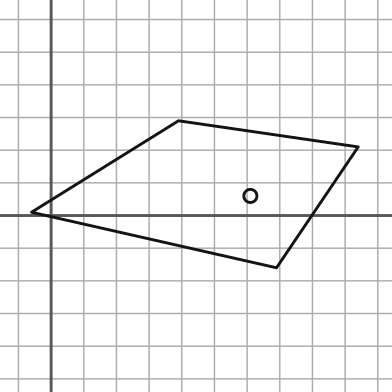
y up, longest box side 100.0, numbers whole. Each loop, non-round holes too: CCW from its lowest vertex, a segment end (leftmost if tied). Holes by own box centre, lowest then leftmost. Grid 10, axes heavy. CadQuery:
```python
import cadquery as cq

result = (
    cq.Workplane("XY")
    .moveTo(69.0, -16.0)
    .lineTo(94.0, 21.0)
    .lineTo(39.0, 29.0)
    .lineTo(-6.0, 1.0)
    .close()
    .moveTo(61.0, 6.0)
    .circle(2.0)
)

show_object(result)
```